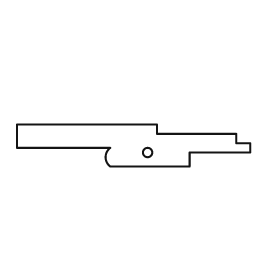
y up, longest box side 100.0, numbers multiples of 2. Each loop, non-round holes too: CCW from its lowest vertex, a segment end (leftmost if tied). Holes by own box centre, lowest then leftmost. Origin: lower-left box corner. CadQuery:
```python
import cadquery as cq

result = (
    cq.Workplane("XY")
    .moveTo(40.0, 0.0)
    .lineTo(74.0, 0.0)
    .lineTo(74.0, 6.0)
    .lineTo(100.0, 6.0)
    .lineTo(100.0, 10.0)
    .lineTo(94.0, 10.0)
    .lineTo(94.0, 14.0)
    .lineTo(60.0, 14.0)
    .lineTo(60.0, 18.0)
    .lineTo(0.0, 18.0)
    .lineTo(0.0, 8.0)
    .lineTo(40.0, 8.0)
    .threePointArc((38.0, 4.0), (40.0, 0.0))
    .close()
    .moveTo(56.0, 6.0)
    .circle(2.0)
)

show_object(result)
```